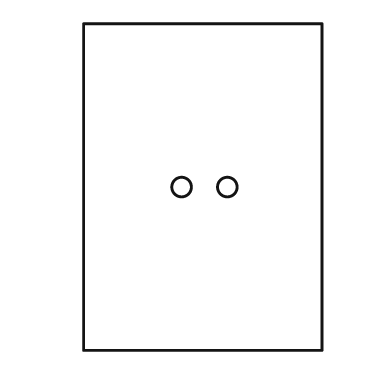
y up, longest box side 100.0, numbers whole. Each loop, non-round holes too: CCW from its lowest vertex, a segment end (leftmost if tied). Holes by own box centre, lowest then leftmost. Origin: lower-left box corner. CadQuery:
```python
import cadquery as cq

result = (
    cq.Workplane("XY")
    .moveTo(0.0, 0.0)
    .lineTo(73.0, 0.0)
    .lineTo(73.0, 100.0)
    .lineTo(0.0, 100.0)
    .close()
    .moveTo(30.0, 50.0)
    .circle(3.0)
    .moveTo(44.0, 50.0)
    .circle(3.0)
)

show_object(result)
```